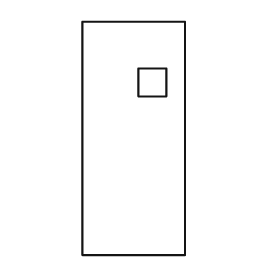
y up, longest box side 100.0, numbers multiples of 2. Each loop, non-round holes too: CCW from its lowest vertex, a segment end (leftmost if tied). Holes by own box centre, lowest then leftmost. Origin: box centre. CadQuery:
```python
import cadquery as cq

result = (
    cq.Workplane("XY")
    .moveTo(-22.0, -50.0)
    .lineTo(22.0, -50.0)
    .lineTo(22.0, 50.0)
    .lineTo(-22.0, 50.0)
    .close()
    .moveTo(2.0, 18.0)
    .lineTo(14.0, 18.0)
    .lineTo(14.0, 30.0)
    .lineTo(2.0, 30.0)
    .close()
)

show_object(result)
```